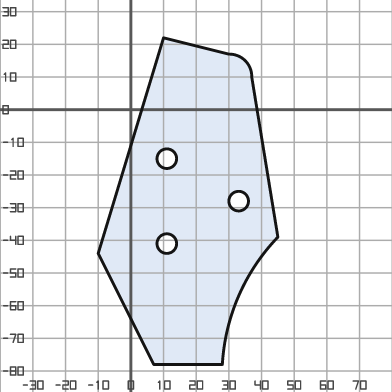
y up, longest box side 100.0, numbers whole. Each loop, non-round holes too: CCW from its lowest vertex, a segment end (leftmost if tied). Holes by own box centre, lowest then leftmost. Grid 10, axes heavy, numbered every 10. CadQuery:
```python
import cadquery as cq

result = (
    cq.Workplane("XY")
    .moveTo(7.0, -78.0)
    .lineTo(28.0, -78.0)
    .threePointArc((33.0, -57.0), (45.0, -39.0))
    .lineTo(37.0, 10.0)
    .threePointArc((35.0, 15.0), (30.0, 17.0))
    .lineTo(10.0, 22.0)
    .lineTo(-10.0, -44.0)
    .close()
    .moveTo(11.0, -41.0)
    .circle(3.0)
    .moveTo(33.0, -28.0)
    .circle(3.0)
    .moveTo(11.0, -15.0)
    .circle(3.0)
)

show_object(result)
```